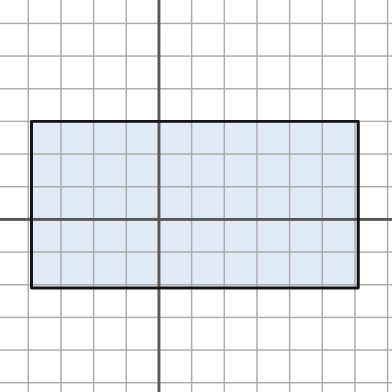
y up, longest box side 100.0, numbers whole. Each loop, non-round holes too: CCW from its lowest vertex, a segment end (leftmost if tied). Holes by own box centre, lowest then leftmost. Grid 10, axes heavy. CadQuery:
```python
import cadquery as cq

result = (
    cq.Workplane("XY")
    .moveTo(-39.0, -21.0)
    .lineTo(61.0, -21.0)
    .lineTo(61.0, 30.0)
    .lineTo(-39.0, 30.0)
    .close()
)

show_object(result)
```